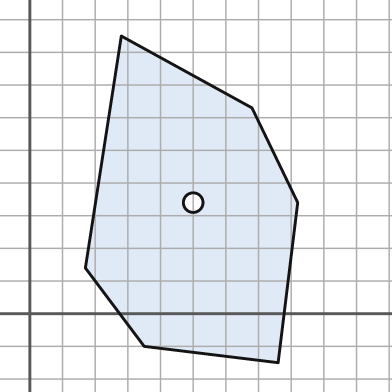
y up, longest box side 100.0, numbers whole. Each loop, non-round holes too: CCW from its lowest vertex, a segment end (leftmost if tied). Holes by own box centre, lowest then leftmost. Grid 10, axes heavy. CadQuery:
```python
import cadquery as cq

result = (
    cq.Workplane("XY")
    .moveTo(76.0, -15.0)
    .lineTo(82.0, 34.0)
    .lineTo(68.0, 63.0)
    .lineTo(28.0, 85.0)
    .lineTo(17.0, 14.0)
    .lineTo(35.0, -10.0)
    .close()
    .moveTo(50.0, 34.0)
    .circle(3.0)
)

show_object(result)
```